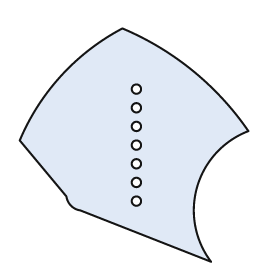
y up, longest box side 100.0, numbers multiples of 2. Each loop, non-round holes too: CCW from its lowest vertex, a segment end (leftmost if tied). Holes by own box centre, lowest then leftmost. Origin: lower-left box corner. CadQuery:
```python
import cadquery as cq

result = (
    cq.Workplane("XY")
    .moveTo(82.0, 0.0)
    .threePointArc((76.0, 32.0), (98.0, 56.0))
    .threePointArc((74.0, 82.0), (44.0, 100.0))
    .threePointArc((18.0, 80.0), (0.0, 52.0))
    .lineTo(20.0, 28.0)
    .threePointArc((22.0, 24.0), (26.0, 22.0))
    .close()
    .moveTo(50.0, 26.0)
    .circle(2.0)
    .moveTo(50.0, 34.0)
    .circle(2.0)
    .moveTo(50.0, 42.0)
    .circle(2.0)
    .moveTo(50.0, 50.0)
    .circle(2.0)
    .moveTo(50.0, 58.0)
    .circle(2.0)
    .moveTo(50.0, 66.0)
    .circle(2.0)
    .moveTo(50.0, 74.0)
    .circle(2.0)
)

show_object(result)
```